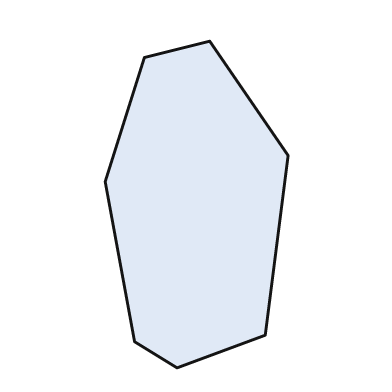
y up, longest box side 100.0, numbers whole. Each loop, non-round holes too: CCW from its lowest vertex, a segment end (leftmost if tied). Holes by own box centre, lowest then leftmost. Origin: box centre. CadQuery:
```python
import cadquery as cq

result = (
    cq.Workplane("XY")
    .moveTo(-6.0, -50.0)
    .lineTo(21.0, -40.0)
    .lineTo(28.0, 15.0)
    .lineTo(4.0, 50.0)
    .lineTo(-16.0, 45.0)
    .lineTo(-28.0, 7.0)
    .lineTo(-19.0, -42.0)
    .close()
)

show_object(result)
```